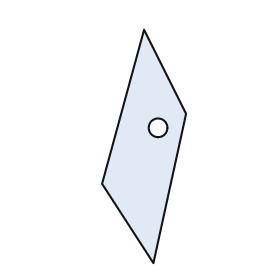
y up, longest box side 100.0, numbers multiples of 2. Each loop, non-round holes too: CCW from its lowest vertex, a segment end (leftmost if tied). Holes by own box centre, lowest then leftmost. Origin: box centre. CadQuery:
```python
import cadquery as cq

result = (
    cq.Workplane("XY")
    .moveTo(4.0, -50.0)
    .lineTo(18.0, 14.0)
    .lineTo(0.0, 50.0)
    .lineTo(-18.0, -16.0)
    .close()
    .moveTo(6.0, 8.0)
    .circle(4.0)
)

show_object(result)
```